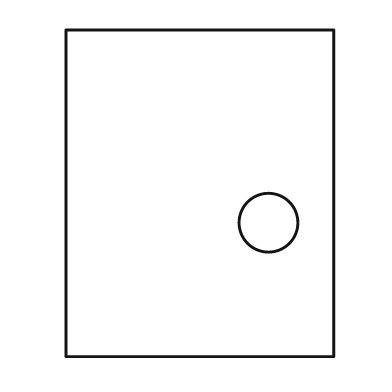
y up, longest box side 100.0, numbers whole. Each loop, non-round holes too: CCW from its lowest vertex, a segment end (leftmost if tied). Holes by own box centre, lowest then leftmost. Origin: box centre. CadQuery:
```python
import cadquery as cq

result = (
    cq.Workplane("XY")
    .moveTo(-41.0, -50.0)
    .lineTo(41.0, -50.0)
    .lineTo(41.0, 50.0)
    .lineTo(-41.0, 50.0)
    .close()
    .moveTo(21.0, -9.0)
    .circle(9.0)
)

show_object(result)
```